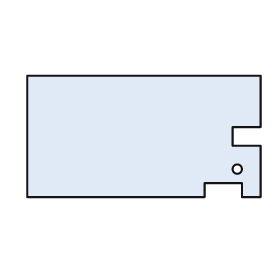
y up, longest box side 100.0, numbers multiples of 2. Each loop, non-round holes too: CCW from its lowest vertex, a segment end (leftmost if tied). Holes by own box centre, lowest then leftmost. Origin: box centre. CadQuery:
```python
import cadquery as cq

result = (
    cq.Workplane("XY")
    .moveTo(-50.0, -26.0)
    .lineTo(26.0, -26.0)
    .lineTo(26.0, -20.0)
    .lineTo(42.0, -20.0)
    .lineTo(42.0, -26.0)
    .lineTo(50.0, -26.0)
    .lineTo(50.0, -4.0)
    .lineTo(38.0, -4.0)
    .lineTo(38.0, 4.0)
    .lineTo(50.0, 4.0)
    .lineTo(50.0, 26.0)
    .lineTo(-50.0, 26.0)
    .close()
    .moveTo(40.0, -14.0)
    .circle(2.0)
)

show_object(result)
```